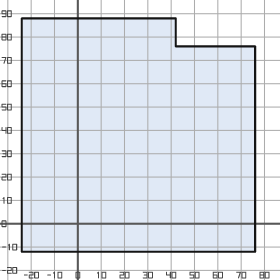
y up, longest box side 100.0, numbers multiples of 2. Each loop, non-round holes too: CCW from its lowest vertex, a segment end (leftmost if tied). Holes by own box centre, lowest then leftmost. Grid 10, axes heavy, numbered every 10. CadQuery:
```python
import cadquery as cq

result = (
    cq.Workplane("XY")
    .moveTo(-24.0, -12.0)
    .lineTo(76.0, -12.0)
    .lineTo(76.0, 76.0)
    .lineTo(42.0, 76.0)
    .lineTo(42.0, 88.0)
    .lineTo(-24.0, 88.0)
    .close()
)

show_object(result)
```